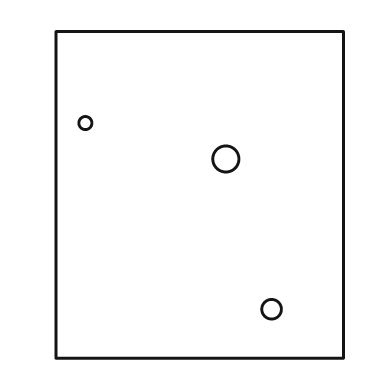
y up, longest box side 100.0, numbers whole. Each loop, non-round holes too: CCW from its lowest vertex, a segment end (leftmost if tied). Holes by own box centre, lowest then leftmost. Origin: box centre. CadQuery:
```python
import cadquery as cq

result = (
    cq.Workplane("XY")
    .moveTo(-44.0, -50.0)
    .lineTo(44.0, -50.0)
    .lineTo(44.0, 50.0)
    .lineTo(-44.0, 50.0)
    .close()
    .moveTo(22.0, -35.0)
    .circle(3.0)
    .moveTo(8.0, 11.0)
    .circle(4.0)
    .moveTo(-35.0, 22.0)
    .circle(2.0)
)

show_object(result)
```